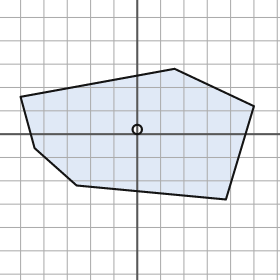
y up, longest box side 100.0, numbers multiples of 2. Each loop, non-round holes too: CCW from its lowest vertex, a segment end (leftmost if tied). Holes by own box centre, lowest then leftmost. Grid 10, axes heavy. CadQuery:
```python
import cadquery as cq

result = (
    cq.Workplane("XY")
    .moveTo(38.0, -28.0)
    .lineTo(50.0, 12.0)
    .lineTo(16.0, 28.0)
    .lineTo(-50.0, 16.0)
    .lineTo(-44.0, -6.0)
    .lineTo(-26.0, -22.0)
    .close()
    .moveTo(0.0, 2.0)
    .circle(2.0)
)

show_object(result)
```